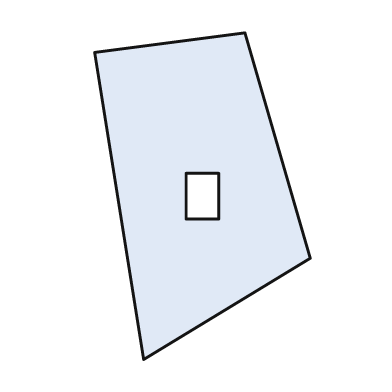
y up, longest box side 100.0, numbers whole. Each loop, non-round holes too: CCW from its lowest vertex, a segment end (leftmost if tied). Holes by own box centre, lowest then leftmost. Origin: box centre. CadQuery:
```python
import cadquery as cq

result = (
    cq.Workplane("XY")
    .moveTo(-18.0, -50.0)
    .lineTo(33.0, -19.0)
    .lineTo(13.0, 50.0)
    .lineTo(-33.0, 44.0)
    .close()
    .moveTo(-5.0, -7.0)
    .lineTo(5.0, -7.0)
    .lineTo(5.0, 7.0)
    .lineTo(-5.0, 7.0)
    .close()
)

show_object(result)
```